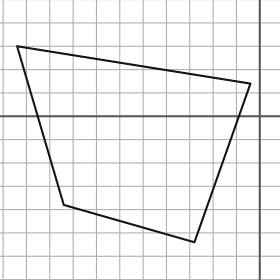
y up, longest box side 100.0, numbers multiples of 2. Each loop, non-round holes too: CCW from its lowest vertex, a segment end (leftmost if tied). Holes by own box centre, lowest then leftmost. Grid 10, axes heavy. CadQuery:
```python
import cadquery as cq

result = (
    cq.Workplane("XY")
    .moveTo(-28.0, -54.0)
    .lineTo(-4.0, 14.0)
    .lineTo(-104.0, 30.0)
    .lineTo(-84.0, -38.0)
    .close()
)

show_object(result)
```